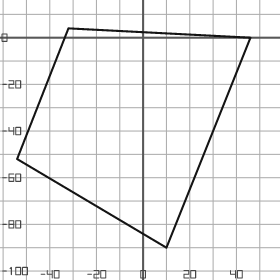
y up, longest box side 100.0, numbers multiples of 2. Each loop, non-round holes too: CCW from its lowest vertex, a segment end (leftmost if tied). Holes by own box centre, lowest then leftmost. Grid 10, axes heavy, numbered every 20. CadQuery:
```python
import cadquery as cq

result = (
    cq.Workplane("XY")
    .moveTo(10.0, -90.0)
    .lineTo(46.0, 0.0)
    .lineTo(-32.0, 4.0)
    .lineTo(-54.0, -52.0)
    .close()
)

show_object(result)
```